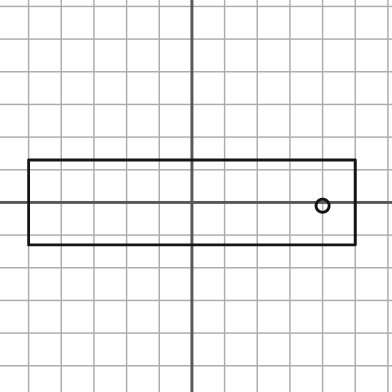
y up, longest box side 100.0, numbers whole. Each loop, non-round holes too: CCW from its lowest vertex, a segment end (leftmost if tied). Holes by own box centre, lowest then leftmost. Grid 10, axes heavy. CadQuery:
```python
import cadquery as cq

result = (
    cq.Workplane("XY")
    .moveTo(-50.0, -13.0)
    .lineTo(50.0, -13.0)
    .lineTo(50.0, 13.0)
    .lineTo(-50.0, 13.0)
    .close()
    .moveTo(40.0, -1.0)
    .circle(2.0)
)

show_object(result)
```